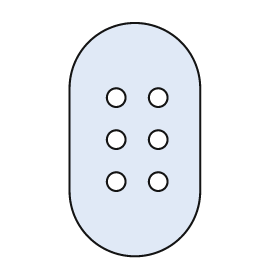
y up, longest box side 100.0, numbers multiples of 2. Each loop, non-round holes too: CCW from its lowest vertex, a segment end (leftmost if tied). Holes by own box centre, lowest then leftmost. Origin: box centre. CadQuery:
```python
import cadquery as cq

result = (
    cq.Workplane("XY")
    .moveTo(-28.0, -22.0)
    .threePointArc((0.0, -50.0), (28.0, -22.0))
    .lineTo(28.0, 22.0)
    .threePointArc((0.0, 50.0), (-28.0, 22.0))
    .close()
    .moveTo(-8.0, -18.0)
    .circle(4.0)
    .moveTo(10.0, -18.0)
    .circle(4.0)
    .moveTo(-8.0, 0.0)
    .circle(4.0)
    .moveTo(10.0, 0.0)
    .circle(4.0)
    .moveTo(-8.0, 18.0)
    .circle(4.0)
    .moveTo(10.0, 18.0)
    .circle(4.0)
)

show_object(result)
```